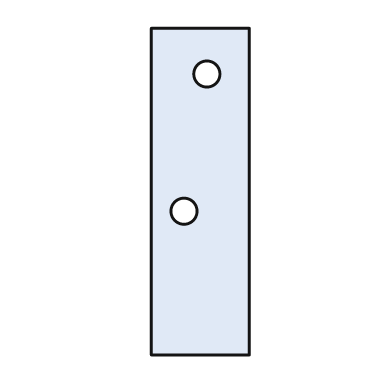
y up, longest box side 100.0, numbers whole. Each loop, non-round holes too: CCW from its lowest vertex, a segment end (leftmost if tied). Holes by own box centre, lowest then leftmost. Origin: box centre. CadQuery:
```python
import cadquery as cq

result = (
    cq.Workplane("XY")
    .moveTo(-15.0, -50.0)
    .lineTo(15.0, -50.0)
    .lineTo(15.0, 50.0)
    .lineTo(-15.0, 50.0)
    .close()
    .moveTo(-5.0, -6.0)
    .circle(4.0)
    .moveTo(2.0, 36.0)
    .circle(4.0)
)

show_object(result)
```